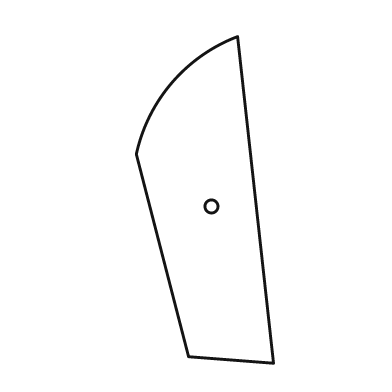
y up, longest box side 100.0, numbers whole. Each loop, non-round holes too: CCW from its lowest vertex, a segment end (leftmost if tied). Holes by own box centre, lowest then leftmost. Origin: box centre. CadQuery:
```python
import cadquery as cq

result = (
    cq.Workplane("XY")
    .moveTo(21.0, -50.0)
    .lineTo(10.0, 50.0)
    .threePointArc((-10.0, 36.0), (-21.0, 14.0))
    .lineTo(-5.0, -48.0)
    .close()
    .moveTo(2.0, -2.0)
    .circle(2.0)
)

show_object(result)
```